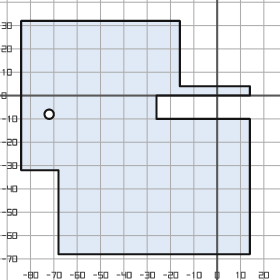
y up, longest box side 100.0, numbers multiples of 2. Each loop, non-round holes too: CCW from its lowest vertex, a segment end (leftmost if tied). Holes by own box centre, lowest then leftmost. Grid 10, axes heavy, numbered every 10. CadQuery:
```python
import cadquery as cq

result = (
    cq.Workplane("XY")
    .moveTo(-68.0, -68.0)
    .lineTo(14.0, -68.0)
    .lineTo(14.0, -10.0)
    .lineTo(-26.0, -10.0)
    .lineTo(-26.0, 0.0)
    .lineTo(14.0, 0.0)
    .lineTo(14.0, 4.0)
    .lineTo(-16.0, 4.0)
    .lineTo(-16.0, 32.0)
    .lineTo(-84.0, 32.0)
    .lineTo(-84.0, -32.0)
    .lineTo(-68.0, -32.0)
    .close()
    .moveTo(-72.0, -8.0)
    .circle(2.0)
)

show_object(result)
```